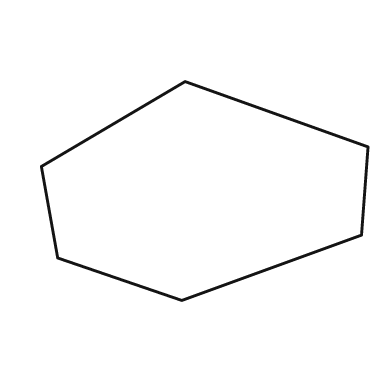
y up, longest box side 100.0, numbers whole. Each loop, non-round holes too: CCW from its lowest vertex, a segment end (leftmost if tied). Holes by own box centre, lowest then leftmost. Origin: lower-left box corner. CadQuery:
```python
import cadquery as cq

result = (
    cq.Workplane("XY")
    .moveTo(43.0, 0.0)
    .lineTo(98.0, 20.0)
    .lineTo(100.0, 47.0)
    .lineTo(44.0, 67.0)
    .lineTo(0.0, 41.0)
    .lineTo(5.0, 13.0)
    .close()
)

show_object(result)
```